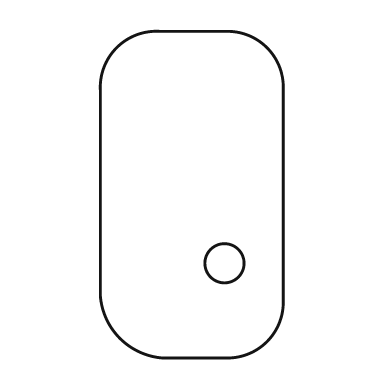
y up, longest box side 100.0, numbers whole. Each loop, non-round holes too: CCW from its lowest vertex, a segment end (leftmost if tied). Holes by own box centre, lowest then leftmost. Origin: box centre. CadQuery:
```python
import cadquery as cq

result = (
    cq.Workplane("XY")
    .moveTo(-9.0, -50.0)
    .lineTo(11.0, -50.0)
    .threePointArc((23.0, -45.0), (28.0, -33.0))
    .lineTo(28.0, 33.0)
    .threePointArc((23.0, 45.0), (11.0, 50.0))
    .lineTo(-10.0, 50.0)
    .threePointArc((-23.0, 45.0), (-28.0, 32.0))
    .lineTo(-28.0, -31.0)
    .threePointArc((-22.0, -44.0), (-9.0, -50.0))
    .close()
    .moveTo(10.0, -21.0)
    .circle(6.0)
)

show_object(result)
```